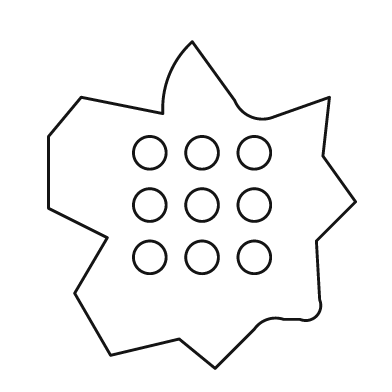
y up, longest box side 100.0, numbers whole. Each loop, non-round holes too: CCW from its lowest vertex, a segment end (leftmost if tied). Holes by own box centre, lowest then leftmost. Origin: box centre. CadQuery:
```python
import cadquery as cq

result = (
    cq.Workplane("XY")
    .moveTo(4.0, -50.0)
    .lineTo(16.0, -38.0)
    .threePointArc((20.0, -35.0), (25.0, -35.0))
    .lineTo(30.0, -35.0)
    .threePointArc((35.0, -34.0), (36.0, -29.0))
    .lineTo(35.0, -11.0)
    .lineTo(47.0, 1.0)
    .lineTo(37.0, 15.0)
    .lineTo(39.0, 33.0)
    .lineTo(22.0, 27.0)
    .threePointArc((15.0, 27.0), (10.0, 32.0))
    .lineTo(-3.0, 50.0)
    .threePointArc((-10.0, 40.0), (-12.0, 28.0))
    .lineTo(-37.0, 33.0)
    .lineTo(-47.0, 21.0)
    .lineTo(-47.0, -1.0)
    .lineTo(-29.0, -10.0)
    .lineTo(-39.0, -27.0)
    .lineTo(-28.0, -46.0)
    .lineTo(-7.0, -41.0)
    .close()
    .moveTo(-16.0, -16.0)
    .circle(5.0)
    .moveTo(0.0, -16.0)
    .circle(5.0)
    .moveTo(16.0, -16.0)
    .circle(5.0)
    .moveTo(-16.0, 0.0)
    .circle(5.0)
    .moveTo(0.0, 0.0)
    .circle(5.0)
    .moveTo(16.0, 0.0)
    .circle(5.0)
    .moveTo(-16.0, 16.0)
    .circle(5.0)
    .moveTo(0.0, 16.0)
    .circle(5.0)
    .moveTo(16.0, 16.0)
    .circle(5.0)
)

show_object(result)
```